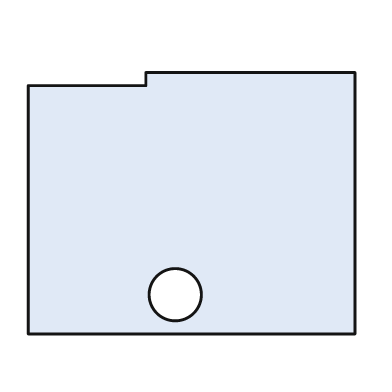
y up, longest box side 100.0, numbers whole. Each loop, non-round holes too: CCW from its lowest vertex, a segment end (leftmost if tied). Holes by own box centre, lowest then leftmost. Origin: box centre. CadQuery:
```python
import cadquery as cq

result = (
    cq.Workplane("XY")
    .moveTo(-50.0, -40.0)
    .lineTo(50.0, -40.0)
    .lineTo(50.0, 40.0)
    .lineTo(-14.0, 40.0)
    .lineTo(-14.0, 36.0)
    .lineTo(-50.0, 36.0)
    .close()
    .moveTo(-5.0, -28.0)
    .circle(8.0)
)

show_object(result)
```